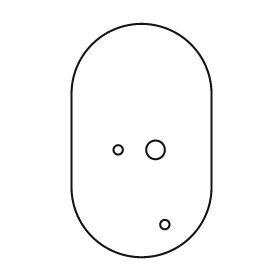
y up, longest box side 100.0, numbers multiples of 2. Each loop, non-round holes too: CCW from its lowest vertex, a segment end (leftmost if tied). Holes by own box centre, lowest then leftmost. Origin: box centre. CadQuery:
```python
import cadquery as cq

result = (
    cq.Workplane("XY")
    .moveTo(-30.0, -20.0)
    .threePointArc((0.0, -50.0), (30.0, -20.0))
    .lineTo(30.0, 20.0)
    .threePointArc((0.0, 50.0), (-30.0, 20.0))
    .close()
    .moveTo(10.0, -36.0)
    .circle(2.0)
    .moveTo(-10.0, -4.0)
    .circle(2.0)
    .moveTo(6.0, -4.0)
    .circle(4.0)
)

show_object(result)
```